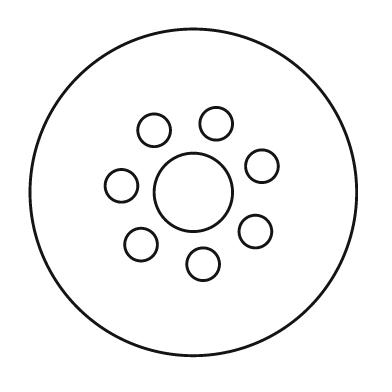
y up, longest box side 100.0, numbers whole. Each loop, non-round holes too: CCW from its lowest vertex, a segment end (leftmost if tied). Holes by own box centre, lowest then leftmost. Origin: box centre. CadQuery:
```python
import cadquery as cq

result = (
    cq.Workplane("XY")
    .moveTo(0.0, 0.0)
    .circle(50.0)
    .moveTo(3.0, -22.0)
    .circle(5.0)
    .moveTo(-16.0, -16.0)
    .circle(5.0)
    .moveTo(19.0, -12.0)
    .circle(5.0)
    .moveTo(0.0, 0.0)
    .circle(12.0)
    .moveTo(-22.0, 2.0)
    .circle(5.0)
    .moveTo(21.0, 8.0)
    .circle(5.0)
    .moveTo(-12.0, 19.0)
    .circle(5.0)
    .moveTo(7.0, 21.0)
    .circle(5.0)
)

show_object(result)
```